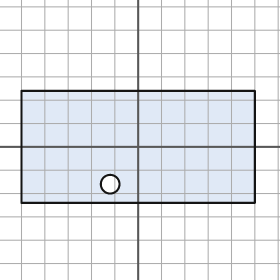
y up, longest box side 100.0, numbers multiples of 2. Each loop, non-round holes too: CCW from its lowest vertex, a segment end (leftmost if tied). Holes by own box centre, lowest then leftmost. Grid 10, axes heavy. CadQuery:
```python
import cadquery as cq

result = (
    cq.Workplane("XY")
    .moveTo(-50.0, -24.0)
    .lineTo(50.0, -24.0)
    .lineTo(50.0, 24.0)
    .lineTo(-50.0, 24.0)
    .close()
    .moveTo(-12.0, -16.0)
    .circle(4.0)
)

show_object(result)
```